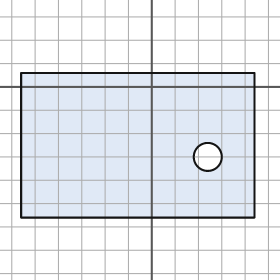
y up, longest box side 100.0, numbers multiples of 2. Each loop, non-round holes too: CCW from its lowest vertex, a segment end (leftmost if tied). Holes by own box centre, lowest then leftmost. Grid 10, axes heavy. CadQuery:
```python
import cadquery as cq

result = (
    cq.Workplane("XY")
    .moveTo(-56.0, -56.0)
    .lineTo(44.0, -56.0)
    .lineTo(44.0, 6.0)
    .lineTo(-56.0, 6.0)
    .close()
    .moveTo(24.0, -30.0)
    .circle(6.0)
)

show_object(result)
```